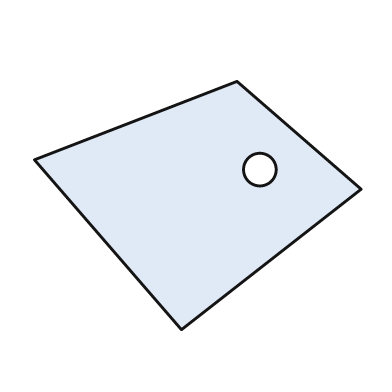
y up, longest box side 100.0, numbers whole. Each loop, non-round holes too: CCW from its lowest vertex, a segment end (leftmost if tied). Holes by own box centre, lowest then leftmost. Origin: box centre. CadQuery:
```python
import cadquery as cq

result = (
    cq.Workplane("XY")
    .moveTo(-5.0, -38.0)
    .lineTo(50.0, 5.0)
    .lineTo(12.0, 38.0)
    .lineTo(-50.0, 14.0)
    .close()
    .moveTo(19.0, 11.0)
    .circle(5.0)
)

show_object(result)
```